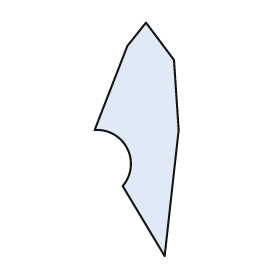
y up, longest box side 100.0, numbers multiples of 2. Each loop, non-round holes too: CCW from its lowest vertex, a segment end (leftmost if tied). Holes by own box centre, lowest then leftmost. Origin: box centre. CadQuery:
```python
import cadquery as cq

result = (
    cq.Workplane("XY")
    .moveTo(12.0, -50.0)
    .lineTo(18.0, 4.0)
    .lineTo(16.0, 34.0)
    .lineTo(4.0, 50.0)
    .lineTo(-4.0, 40.0)
    .lineTo(-18.0, 4.0)
    .threePointArc((-4.0, -4.0), (-6.0, -20.0))
    .close()
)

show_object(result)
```